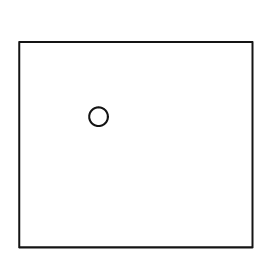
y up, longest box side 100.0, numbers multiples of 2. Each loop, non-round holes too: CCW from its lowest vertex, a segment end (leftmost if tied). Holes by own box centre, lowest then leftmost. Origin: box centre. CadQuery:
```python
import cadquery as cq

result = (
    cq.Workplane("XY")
    .moveTo(-50.0, -44.0)
    .lineTo(50.0, -44.0)
    .lineTo(50.0, 44.0)
    .lineTo(-50.0, 44.0)
    .close()
    .moveTo(-16.0, 12.0)
    .circle(4.0)
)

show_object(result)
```